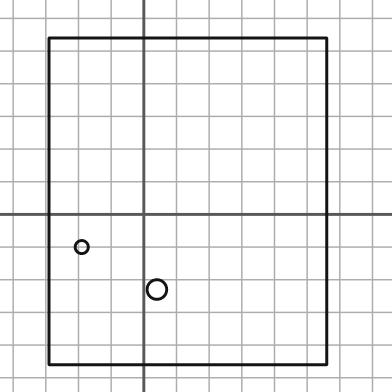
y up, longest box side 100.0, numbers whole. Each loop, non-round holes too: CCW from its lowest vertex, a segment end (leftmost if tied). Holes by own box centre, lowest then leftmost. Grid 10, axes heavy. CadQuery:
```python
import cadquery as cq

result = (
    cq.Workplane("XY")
    .moveTo(-29.0, -46.0)
    .lineTo(56.0, -46.0)
    .lineTo(56.0, 54.0)
    .lineTo(-29.0, 54.0)
    .close()
    .moveTo(4.0, -23.0)
    .circle(3.0)
    .moveTo(-19.0, -10.0)
    .circle(2.0)
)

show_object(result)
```